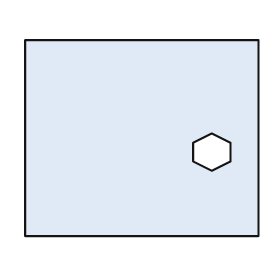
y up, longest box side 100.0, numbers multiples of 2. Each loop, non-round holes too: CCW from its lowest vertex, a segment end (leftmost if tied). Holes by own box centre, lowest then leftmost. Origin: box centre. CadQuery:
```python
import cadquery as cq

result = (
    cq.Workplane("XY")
    .moveTo(-50.0, -42.0)
    .lineTo(50.0, -42.0)
    .lineTo(50.0, 42.0)
    .lineTo(-50.0, 42.0)
    .close()
    .moveTo(30.0, -14.0)
    .lineTo(38.0, -10.0)
    .lineTo(38.0, -2.0)
    .lineTo(30.0, 2.0)
    .lineTo(22.0, -2.0)
    .lineTo(22.0, -10.0)
    .close()
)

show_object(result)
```